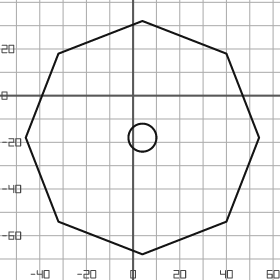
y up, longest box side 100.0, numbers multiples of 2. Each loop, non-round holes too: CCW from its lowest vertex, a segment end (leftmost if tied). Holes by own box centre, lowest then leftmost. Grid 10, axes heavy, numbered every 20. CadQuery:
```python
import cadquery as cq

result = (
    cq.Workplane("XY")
    .moveTo(4.0, -68.0)
    .lineTo(40.0, -54.0)
    .lineTo(54.0, -18.0)
    .lineTo(40.0, 18.0)
    .lineTo(4.0, 32.0)
    .lineTo(-32.0, 18.0)
    .lineTo(-46.0, -18.0)
    .lineTo(-32.0, -54.0)
    .close()
    .moveTo(4.0, -18.0)
    .circle(6.0)
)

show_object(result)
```